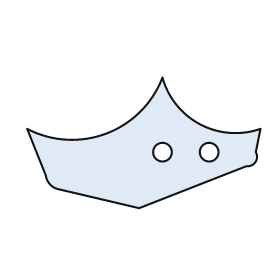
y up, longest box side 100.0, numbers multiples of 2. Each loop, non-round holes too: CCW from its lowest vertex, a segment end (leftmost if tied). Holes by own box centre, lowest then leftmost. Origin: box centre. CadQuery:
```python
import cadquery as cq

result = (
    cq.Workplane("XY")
    .moveTo(-2.0, -28.0)
    .lineTo(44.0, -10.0)
    .threePointArc((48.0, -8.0), (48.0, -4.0))
    .lineTo(50.0, 6.0)
    .threePointArc((24.0, 8.0), (8.0, 28.0))
    .threePointArc((-16.0, 4.0), (-50.0, 6.0))
    .lineTo(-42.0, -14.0)
    .threePointArc((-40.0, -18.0), (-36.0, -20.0))
    .close()
    .moveTo(8.0, -4.0)
    .circle(4.0)
    .moveTo(28.0, -4.0)
    .circle(4.0)
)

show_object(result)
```